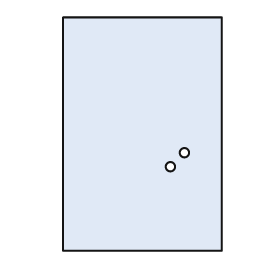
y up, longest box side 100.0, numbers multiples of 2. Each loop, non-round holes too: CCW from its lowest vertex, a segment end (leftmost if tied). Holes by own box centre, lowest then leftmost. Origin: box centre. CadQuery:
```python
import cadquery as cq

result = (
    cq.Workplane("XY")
    .moveTo(-34.0, -50.0)
    .lineTo(34.0, -50.0)
    .lineTo(34.0, 50.0)
    .lineTo(-34.0, 50.0)
    .close()
    .moveTo(12.0, -14.0)
    .circle(2.0)
    .moveTo(18.0, -8.0)
    .circle(2.0)
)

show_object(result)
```